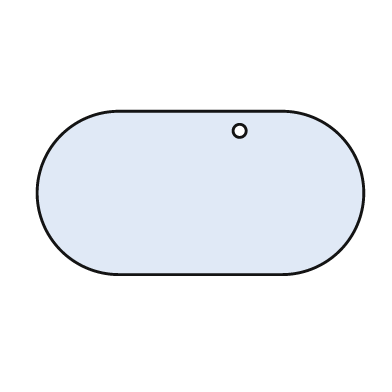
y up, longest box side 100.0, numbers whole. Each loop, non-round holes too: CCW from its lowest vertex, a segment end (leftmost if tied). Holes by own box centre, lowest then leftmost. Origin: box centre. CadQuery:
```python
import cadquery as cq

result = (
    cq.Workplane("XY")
    .moveTo(-25.0, -25.0)
    .lineTo(25.0, -25.0)
    .threePointArc((50.0, 0.0), (25.0, 25.0))
    .lineTo(-25.0, 25.0)
    .threePointArc((-50.0, 0.0), (-25.0, -25.0))
    .close()
    .moveTo(12.0, 19.0)
    .circle(2.0)
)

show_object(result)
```